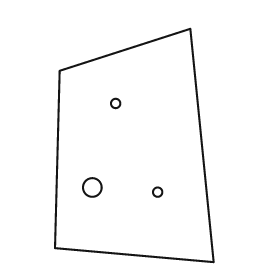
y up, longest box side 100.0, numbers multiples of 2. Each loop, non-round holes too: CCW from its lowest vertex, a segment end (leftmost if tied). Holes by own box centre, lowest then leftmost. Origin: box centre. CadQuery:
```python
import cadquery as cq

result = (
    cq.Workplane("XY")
    .moveTo(34.0, -50.0)
    .lineTo(24.0, 50.0)
    .lineTo(-32.0, 32.0)
    .lineTo(-34.0, -44.0)
    .close()
    .moveTo(10.0, -20.0)
    .circle(2.0)
    .moveTo(-18.0, -18.0)
    .circle(4.0)
    .moveTo(-8.0, 18.0)
    .circle(2.0)
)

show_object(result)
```